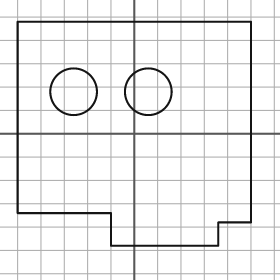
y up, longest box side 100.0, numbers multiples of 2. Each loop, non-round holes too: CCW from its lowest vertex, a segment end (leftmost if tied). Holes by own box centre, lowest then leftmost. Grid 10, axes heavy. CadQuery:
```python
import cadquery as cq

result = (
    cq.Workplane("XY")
    .moveTo(-10.0, -48.0)
    .lineTo(36.0, -48.0)
    .lineTo(36.0, -38.0)
    .lineTo(50.0, -38.0)
    .lineTo(50.0, 48.0)
    .lineTo(-50.0, 48.0)
    .lineTo(-50.0, -34.0)
    .lineTo(-10.0, -34.0)
    .close()
    .moveTo(-26.0, 18.0)
    .circle(10.0)
    .moveTo(6.0, 18.0)
    .circle(10.0)
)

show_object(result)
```